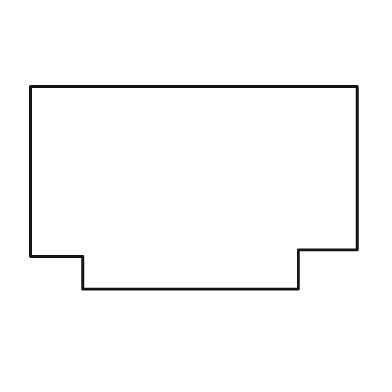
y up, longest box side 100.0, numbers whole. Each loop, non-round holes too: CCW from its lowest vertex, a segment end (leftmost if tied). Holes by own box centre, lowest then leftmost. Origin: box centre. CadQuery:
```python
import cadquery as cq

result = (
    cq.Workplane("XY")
    .moveTo(-34.0, -31.0)
    .lineTo(32.0, -31.0)
    .lineTo(32.0, -19.0)
    .lineTo(50.0, -19.0)
    .lineTo(50.0, 31.0)
    .lineTo(-50.0, 31.0)
    .lineTo(-50.0, -21.0)
    .lineTo(-34.0, -21.0)
    .close()
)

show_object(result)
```